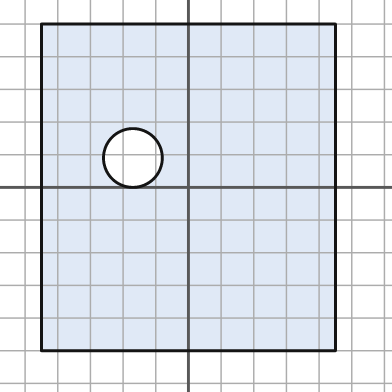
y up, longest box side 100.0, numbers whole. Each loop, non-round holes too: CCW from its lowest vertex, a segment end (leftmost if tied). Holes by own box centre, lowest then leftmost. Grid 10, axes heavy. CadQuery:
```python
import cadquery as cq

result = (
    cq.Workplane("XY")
    .moveTo(-45.0, -50.0)
    .lineTo(45.0, -50.0)
    .lineTo(45.0, 50.0)
    .lineTo(-45.0, 50.0)
    .close()
    .moveTo(-17.0, 9.0)
    .circle(9.0)
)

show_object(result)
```